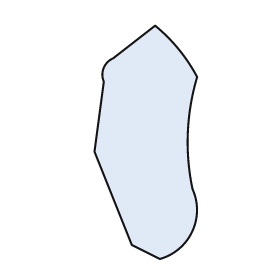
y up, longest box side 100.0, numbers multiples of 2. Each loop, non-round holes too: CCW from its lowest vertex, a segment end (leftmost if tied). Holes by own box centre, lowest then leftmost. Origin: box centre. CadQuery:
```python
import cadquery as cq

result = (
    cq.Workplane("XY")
    .moveTo(6.0, -50.0)
    .threePointArc((20.0, -38.0), (20.0, -20.0))
    .threePointArc((18.0, 4.0), (22.0, 28.0))
    .threePointArc((14.0, 40.0), (4.0, 50.0))
    .lineTo(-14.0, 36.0)
    .threePointArc((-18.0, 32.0), (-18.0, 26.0))
    .lineTo(-22.0, -4.0)
    .lineTo(-6.0, -44.0)
    .close()
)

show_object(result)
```